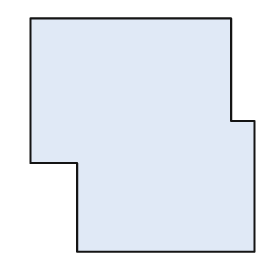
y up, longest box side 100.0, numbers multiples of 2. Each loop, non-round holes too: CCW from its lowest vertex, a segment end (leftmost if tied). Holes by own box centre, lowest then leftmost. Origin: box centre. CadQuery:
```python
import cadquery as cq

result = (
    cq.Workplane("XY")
    .moveTo(-28.0, -50.0)
    .lineTo(48.0, -50.0)
    .lineTo(48.0, 6.0)
    .lineTo(38.0, 6.0)
    .lineTo(38.0, 50.0)
    .lineTo(-48.0, 50.0)
    .lineTo(-48.0, -12.0)
    .lineTo(-28.0, -12.0)
    .close()
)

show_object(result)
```